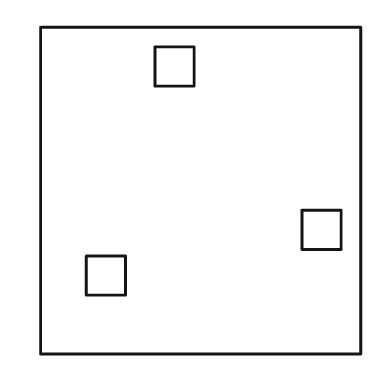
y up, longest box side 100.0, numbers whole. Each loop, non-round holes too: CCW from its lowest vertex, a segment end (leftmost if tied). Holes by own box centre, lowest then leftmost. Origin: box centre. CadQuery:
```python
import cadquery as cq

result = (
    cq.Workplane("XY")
    .moveTo(-49.0, -50.0)
    .lineTo(49.0, -50.0)
    .lineTo(49.0, 50.0)
    .lineTo(-49.0, 50.0)
    .close()
    .moveTo(-35.0, -32.0)
    .lineTo(-23.0, -32.0)
    .lineTo(-23.0, -20.0)
    .lineTo(-35.0, -20.0)
    .close()
    .moveTo(31.0, -18.0)
    .lineTo(43.0, -18.0)
    .lineTo(43.0, -6.0)
    .lineTo(31.0, -6.0)
    .close()
    .moveTo(-14.0, 32.0)
    .lineTo(-2.0, 32.0)
    .lineTo(-2.0, 44.0)
    .lineTo(-14.0, 44.0)
    .close()
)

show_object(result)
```